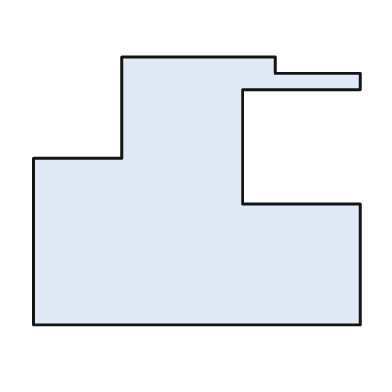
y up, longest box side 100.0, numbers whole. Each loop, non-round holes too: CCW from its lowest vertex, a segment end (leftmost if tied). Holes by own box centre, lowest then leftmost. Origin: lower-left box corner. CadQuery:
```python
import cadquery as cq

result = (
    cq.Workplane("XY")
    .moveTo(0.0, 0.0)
    .lineTo(100.0, 0.0)
    .lineTo(100.0, 37.0)
    .lineTo(64.0, 37.0)
    .lineTo(64.0, 72.0)
    .lineTo(100.0, 72.0)
    .lineTo(100.0, 77.0)
    .lineTo(74.0, 77.0)
    .lineTo(74.0, 82.0)
    .lineTo(27.0, 82.0)
    .lineTo(27.0, 51.0)
    .lineTo(0.0, 51.0)
    .close()
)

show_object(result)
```